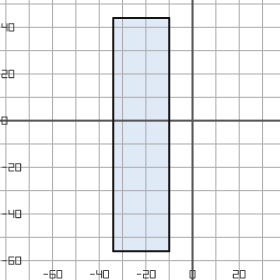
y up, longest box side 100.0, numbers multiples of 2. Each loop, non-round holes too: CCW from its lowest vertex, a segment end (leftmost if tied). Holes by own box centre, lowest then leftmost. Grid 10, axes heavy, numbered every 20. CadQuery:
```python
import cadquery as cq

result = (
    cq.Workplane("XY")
    .moveTo(-34.0, -56.0)
    .lineTo(-10.0, -56.0)
    .lineTo(-10.0, 44.0)
    .lineTo(-34.0, 44.0)
    .close()
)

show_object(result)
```